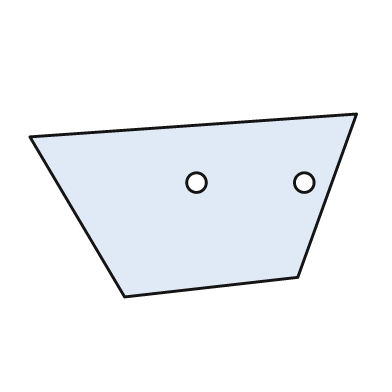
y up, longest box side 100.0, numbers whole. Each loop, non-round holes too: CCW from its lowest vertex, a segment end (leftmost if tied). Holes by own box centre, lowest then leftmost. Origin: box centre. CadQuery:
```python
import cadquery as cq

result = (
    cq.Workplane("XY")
    .moveTo(-21.0, -28.0)
    .lineTo(32.0, -22.0)
    .lineTo(50.0, 28.0)
    .lineTo(-50.0, 21.0)
    .close()
    .moveTo(1.0, 7.0)
    .circle(3.0)
    .moveTo(34.0, 7.0)
    .circle(3.0)
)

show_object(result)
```